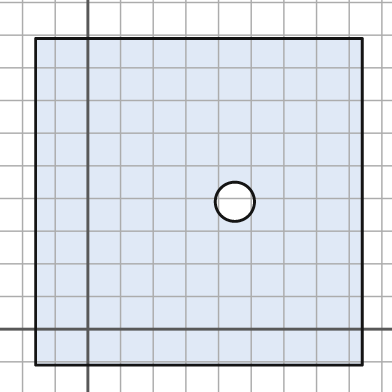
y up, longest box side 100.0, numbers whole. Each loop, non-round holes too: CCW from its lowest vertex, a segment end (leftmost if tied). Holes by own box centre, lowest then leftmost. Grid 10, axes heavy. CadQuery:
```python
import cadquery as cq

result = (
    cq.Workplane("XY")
    .moveTo(-16.0, -11.0)
    .lineTo(84.0, -11.0)
    .lineTo(84.0, 89.0)
    .lineTo(-16.0, 89.0)
    .close()
    .moveTo(45.0, 39.0)
    .circle(6.0)
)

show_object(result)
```